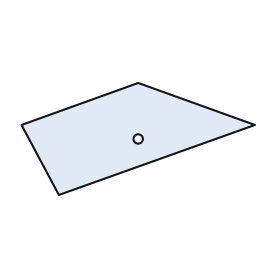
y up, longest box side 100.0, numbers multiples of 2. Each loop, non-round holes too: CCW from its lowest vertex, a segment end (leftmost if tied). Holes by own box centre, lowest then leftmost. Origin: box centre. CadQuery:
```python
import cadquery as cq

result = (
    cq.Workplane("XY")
    .moveTo(-34.0, -24.0)
    .lineTo(50.0, 6.0)
    .lineTo(0.0, 24.0)
    .lineTo(-50.0, 6.0)
    .close()
    .moveTo(0.0, 0.0)
    .circle(2.0)
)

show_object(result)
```